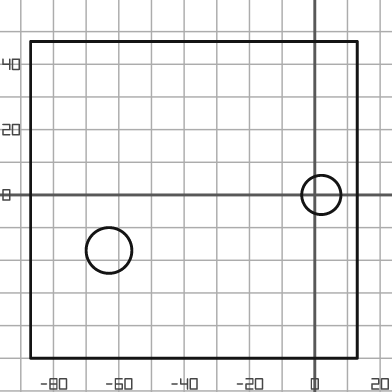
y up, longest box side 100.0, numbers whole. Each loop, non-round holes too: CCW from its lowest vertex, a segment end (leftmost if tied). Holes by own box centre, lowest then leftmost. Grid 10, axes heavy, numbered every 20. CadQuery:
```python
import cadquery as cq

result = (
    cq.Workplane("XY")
    .moveTo(-87.0, -50.0)
    .lineTo(13.0, -50.0)
    .lineTo(13.0, 47.0)
    .lineTo(-87.0, 47.0)
    .close()
    .moveTo(-63.0, -17.0)
    .circle(7.0)
    .moveTo(2.0, 0.0)
    .circle(6.0)
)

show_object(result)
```